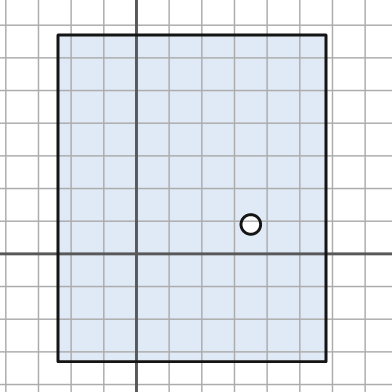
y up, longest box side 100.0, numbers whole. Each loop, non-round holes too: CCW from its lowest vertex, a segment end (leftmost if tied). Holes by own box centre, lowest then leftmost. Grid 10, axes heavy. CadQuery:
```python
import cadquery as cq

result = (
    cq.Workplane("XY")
    .moveTo(-24.0, -33.0)
    .lineTo(58.0, -33.0)
    .lineTo(58.0, 67.0)
    .lineTo(-24.0, 67.0)
    .close()
    .moveTo(35.0, 9.0)
    .circle(3.0)
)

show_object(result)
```